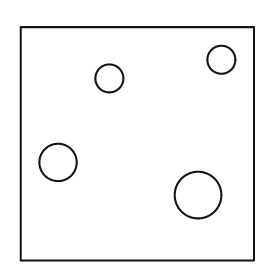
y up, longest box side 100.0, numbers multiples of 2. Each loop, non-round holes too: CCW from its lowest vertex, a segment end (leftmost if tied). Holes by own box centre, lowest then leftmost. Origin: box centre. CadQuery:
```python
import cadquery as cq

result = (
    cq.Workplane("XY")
    .moveTo(-50.0, -50.0)
    .lineTo(50.0, -50.0)
    .lineTo(50.0, 50.0)
    .lineTo(-50.0, 50.0)
    .close()
    .moveTo(26.0, -22.0)
    .circle(10.0)
    .moveTo(-34.0, -8.0)
    .circle(8.0)
    .moveTo(-12.0, 28.0)
    .circle(6.0)
    .moveTo(36.0, 36.0)
    .circle(6.0)
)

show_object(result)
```